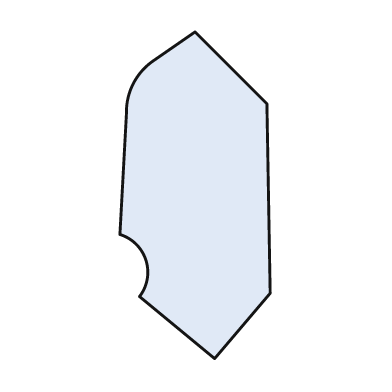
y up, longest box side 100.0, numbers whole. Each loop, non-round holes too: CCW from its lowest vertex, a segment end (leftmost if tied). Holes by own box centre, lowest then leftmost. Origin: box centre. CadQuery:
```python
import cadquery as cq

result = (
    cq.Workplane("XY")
    .moveTo(6.0, -50.0)
    .lineTo(23.0, -30.0)
    .lineTo(22.0, 28.0)
    .lineTo(0.0, 50.0)
    .lineTo(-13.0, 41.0)
    .threePointArc((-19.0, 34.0), (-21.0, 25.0))
    .lineTo(-23.0, -12.0)
    .threePointArc((-15.0, -20.0), (-17.0, -31.0))
    .close()
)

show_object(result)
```